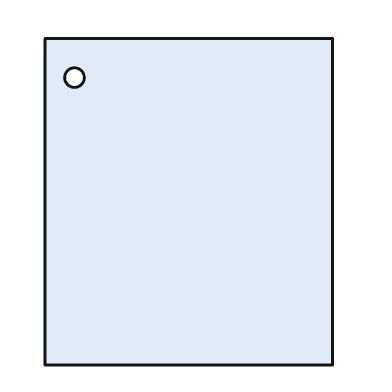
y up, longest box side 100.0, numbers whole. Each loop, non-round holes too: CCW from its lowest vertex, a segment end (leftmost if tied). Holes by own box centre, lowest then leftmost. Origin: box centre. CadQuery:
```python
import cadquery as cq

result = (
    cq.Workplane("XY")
    .moveTo(-44.0, -50.0)
    .lineTo(44.0, -50.0)
    .lineTo(44.0, 50.0)
    .lineTo(-44.0, 50.0)
    .close()
    .moveTo(-35.0, 38.0)
    .circle(3.0)
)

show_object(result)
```